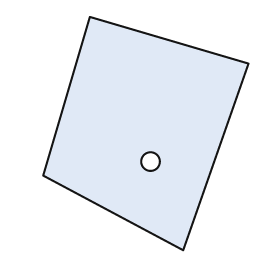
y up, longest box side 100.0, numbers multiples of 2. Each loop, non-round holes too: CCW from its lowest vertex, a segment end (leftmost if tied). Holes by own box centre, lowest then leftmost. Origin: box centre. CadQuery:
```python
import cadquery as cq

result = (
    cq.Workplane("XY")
    .moveTo(16.0, -50.0)
    .lineTo(44.0, 30.0)
    .lineTo(-24.0, 50.0)
    .lineTo(-44.0, -18.0)
    .close()
    .moveTo(2.0, -12.0)
    .circle(4.0)
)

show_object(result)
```